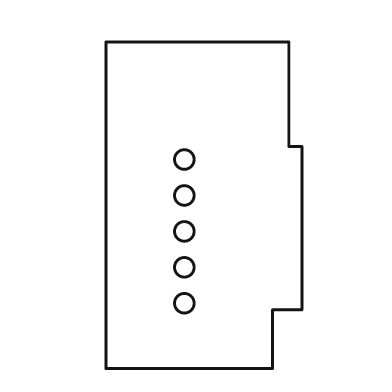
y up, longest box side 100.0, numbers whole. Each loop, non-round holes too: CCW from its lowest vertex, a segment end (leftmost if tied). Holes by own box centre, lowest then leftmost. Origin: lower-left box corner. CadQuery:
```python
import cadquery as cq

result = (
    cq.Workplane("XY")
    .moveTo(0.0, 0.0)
    .lineTo(51.0, 0.0)
    .lineTo(51.0, 18.0)
    .lineTo(60.0, 18.0)
    .lineTo(60.0, 68.0)
    .lineTo(56.0, 68.0)
    .lineTo(56.0, 100.0)
    .lineTo(0.0, 100.0)
    .close()
    .moveTo(24.0, 20.0)
    .circle(3.0)
    .moveTo(24.0, 31.0)
    .circle(3.0)
    .moveTo(24.0, 42.0)
    .circle(3.0)
    .moveTo(24.0, 53.0)
    .circle(3.0)
    .moveTo(24.0, 64.0)
    .circle(3.0)
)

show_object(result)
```